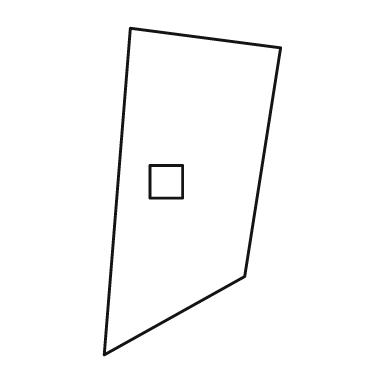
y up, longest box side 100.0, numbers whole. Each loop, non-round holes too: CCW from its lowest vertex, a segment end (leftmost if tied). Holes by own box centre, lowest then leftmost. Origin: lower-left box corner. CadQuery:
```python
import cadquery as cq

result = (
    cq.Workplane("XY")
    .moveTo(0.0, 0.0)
    .lineTo(43.0, 24.0)
    .lineTo(54.0, 94.0)
    .lineTo(8.0, 100.0)
    .close()
    .moveTo(14.0, 48.0)
    .lineTo(24.0, 48.0)
    .lineTo(24.0, 58.0)
    .lineTo(14.0, 58.0)
    .close()
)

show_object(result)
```